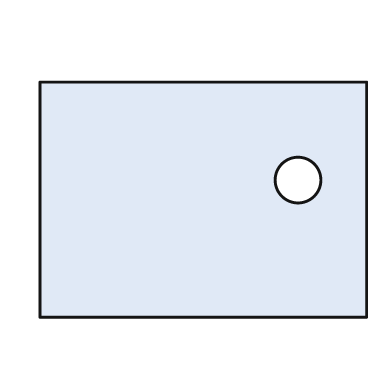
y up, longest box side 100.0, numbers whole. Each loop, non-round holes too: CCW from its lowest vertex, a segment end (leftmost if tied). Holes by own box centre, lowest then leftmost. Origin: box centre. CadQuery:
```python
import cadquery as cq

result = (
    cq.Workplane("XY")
    .moveTo(-50.0, -36.0)
    .lineTo(50.0, -36.0)
    .lineTo(50.0, 36.0)
    .lineTo(-50.0, 36.0)
    .close()
    .moveTo(29.0, 6.0)
    .circle(7.0)
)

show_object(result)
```